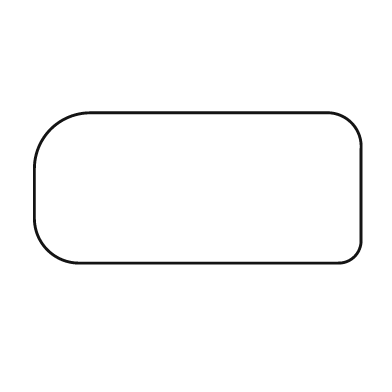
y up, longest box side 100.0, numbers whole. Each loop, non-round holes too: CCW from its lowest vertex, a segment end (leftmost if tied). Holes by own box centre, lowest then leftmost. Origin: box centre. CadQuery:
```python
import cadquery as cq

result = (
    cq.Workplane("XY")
    .moveTo(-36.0, -23.0)
    .lineTo(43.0, -23.0)
    .threePointArc((48.0, -21.0), (50.0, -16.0))
    .lineTo(50.0, 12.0)
    .threePointArc((47.0, 20.0), (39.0, 23.0))
    .lineTo(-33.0, 23.0)
    .threePointArc((-45.0, 18.0), (-50.0, 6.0))
    .lineTo(-50.0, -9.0)
    .threePointArc((-46.0, -19.0), (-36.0, -23.0))
    .close()
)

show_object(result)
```